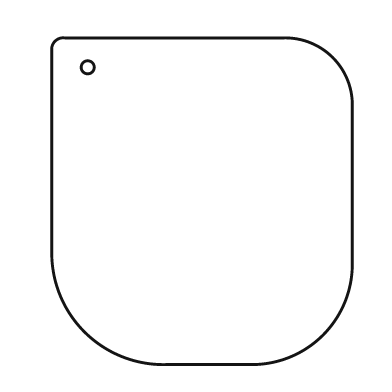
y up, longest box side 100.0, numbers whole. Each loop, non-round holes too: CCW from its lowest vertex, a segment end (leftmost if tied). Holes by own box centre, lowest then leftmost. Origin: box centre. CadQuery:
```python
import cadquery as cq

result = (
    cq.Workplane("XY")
    .moveTo(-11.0, -50.0)
    .lineTo(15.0, -50.0)
    .threePointArc((37.0, -41.0), (46.0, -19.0))
    .lineTo(46.0, 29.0)
    .threePointArc((40.0, 44.0), (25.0, 50.0))
    .lineTo(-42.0, 50.0)
    .threePointArc((-45.0, 49.0), (-46.0, 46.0))
    .lineTo(-46.0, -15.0)
    .threePointArc((-36.0, -40.0), (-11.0, -50.0))
    .close()
    .moveTo(-35.0, 41.0)
    .circle(2.0)
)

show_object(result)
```